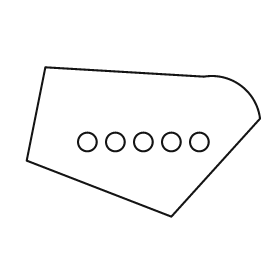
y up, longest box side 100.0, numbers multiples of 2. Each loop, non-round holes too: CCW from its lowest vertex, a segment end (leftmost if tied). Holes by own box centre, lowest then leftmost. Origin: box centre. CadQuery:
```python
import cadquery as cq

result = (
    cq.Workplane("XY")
    .moveTo(12.0, -32.0)
    .lineTo(50.0, 10.0)
    .threePointArc((42.0, 24.0), (26.0, 28.0))
    .lineTo(-42.0, 32.0)
    .lineTo(-50.0, -8.0)
    .close()
    .moveTo(-24.0, 0.0)
    .circle(4.0)
    .moveTo(-12.0, 0.0)
    .circle(4.0)
    .moveTo(0.0, 0.0)
    .circle(4.0)
    .moveTo(12.0, 0.0)
    .circle(4.0)
    .moveTo(24.0, 0.0)
    .circle(4.0)
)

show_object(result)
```